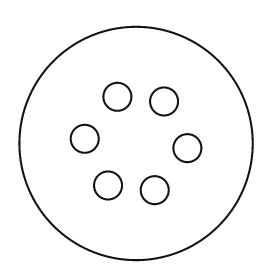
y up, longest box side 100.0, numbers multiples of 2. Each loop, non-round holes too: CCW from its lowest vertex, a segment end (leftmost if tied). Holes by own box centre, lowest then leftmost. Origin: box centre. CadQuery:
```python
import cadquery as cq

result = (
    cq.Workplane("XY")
    .moveTo(0.0, 0.0)
    .circle(50.0)
    .moveTo(8.0, -20.0)
    .circle(6.0)
    .moveTo(-12.0, -18.0)
    .circle(6.0)
    .moveTo(22.0, -2.0)
    .circle(6.0)
    .moveTo(-22.0, 2.0)
    .circle(6.0)
    .moveTo(12.0, 18.0)
    .circle(6.0)
    .moveTo(-8.0, 20.0)
    .circle(6.0)
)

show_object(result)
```